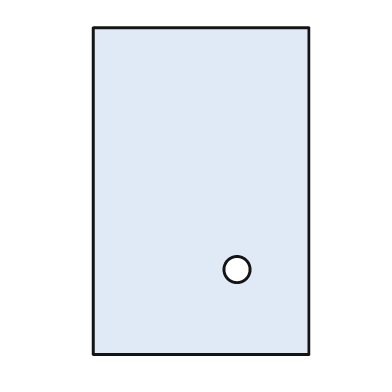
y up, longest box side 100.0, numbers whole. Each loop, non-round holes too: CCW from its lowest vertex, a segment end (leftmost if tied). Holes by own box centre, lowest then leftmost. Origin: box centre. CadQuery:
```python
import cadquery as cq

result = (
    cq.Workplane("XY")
    .moveTo(-33.0, -50.0)
    .lineTo(33.0, -50.0)
    .lineTo(33.0, 50.0)
    .lineTo(-33.0, 50.0)
    .close()
    .moveTo(11.0, -24.0)
    .circle(4.0)
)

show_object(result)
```